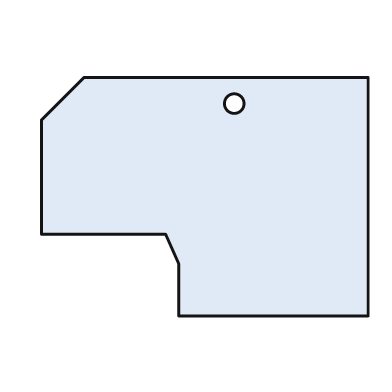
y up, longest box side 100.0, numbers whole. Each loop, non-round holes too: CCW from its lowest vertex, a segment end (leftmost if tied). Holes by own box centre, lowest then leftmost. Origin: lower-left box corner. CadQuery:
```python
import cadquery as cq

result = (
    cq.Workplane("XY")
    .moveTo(42.0, 0.0)
    .lineTo(100.0, 0.0)
    .lineTo(100.0, 73.0)
    .lineTo(13.0, 73.0)
    .lineTo(0.0, 60.0)
    .lineTo(0.0, 25.0)
    .lineTo(38.0, 25.0)
    .lineTo(42.0, 16.0)
    .close()
    .moveTo(59.0, 65.0)
    .circle(3.0)
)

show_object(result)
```